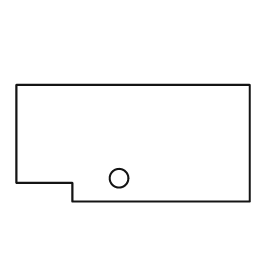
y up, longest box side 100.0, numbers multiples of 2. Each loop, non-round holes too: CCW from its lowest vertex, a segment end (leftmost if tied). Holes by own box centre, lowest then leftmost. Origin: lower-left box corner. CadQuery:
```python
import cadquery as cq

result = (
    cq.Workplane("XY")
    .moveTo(24.0, 0.0)
    .lineTo(100.0, 0.0)
    .lineTo(100.0, 50.0)
    .lineTo(0.0, 50.0)
    .lineTo(0.0, 8.0)
    .lineTo(24.0, 8.0)
    .close()
    .moveTo(44.0, 10.0)
    .circle(4.0)
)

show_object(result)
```